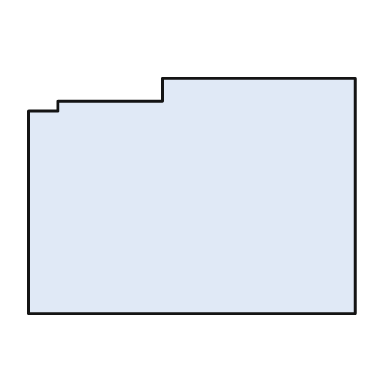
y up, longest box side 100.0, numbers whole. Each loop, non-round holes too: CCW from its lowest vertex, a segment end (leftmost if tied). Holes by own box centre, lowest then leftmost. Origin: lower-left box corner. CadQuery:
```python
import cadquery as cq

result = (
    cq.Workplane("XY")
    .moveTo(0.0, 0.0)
    .lineTo(100.0, 0.0)
    .lineTo(100.0, 72.0)
    .lineTo(41.0, 72.0)
    .lineTo(41.0, 65.0)
    .lineTo(9.0, 65.0)
    .lineTo(9.0, 62.0)
    .lineTo(0.0, 62.0)
    .close()
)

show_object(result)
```